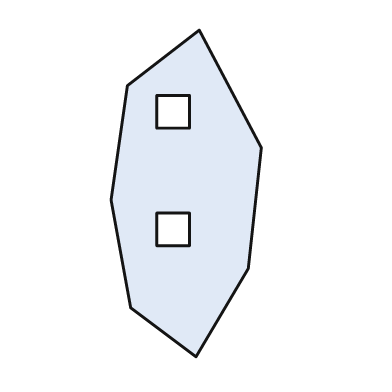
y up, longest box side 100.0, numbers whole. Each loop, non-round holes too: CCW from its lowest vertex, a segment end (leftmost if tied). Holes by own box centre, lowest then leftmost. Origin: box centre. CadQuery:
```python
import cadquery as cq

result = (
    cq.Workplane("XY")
    .moveTo(3.0, -50.0)
    .lineTo(19.0, -23.0)
    .lineTo(23.0, 14.0)
    .lineTo(4.0, 50.0)
    .lineTo(-18.0, 33.0)
    .lineTo(-23.0, -2.0)
    .lineTo(-17.0, -35.0)
    .close()
    .moveTo(-9.0, -16.0)
    .lineTo(1.0, -16.0)
    .lineTo(1.0, -6.0)
    .lineTo(-9.0, -6.0)
    .close()
    .moveTo(-9.0, 20.0)
    .lineTo(1.0, 20.0)
    .lineTo(1.0, 30.0)
    .lineTo(-9.0, 30.0)
    .close()
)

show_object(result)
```